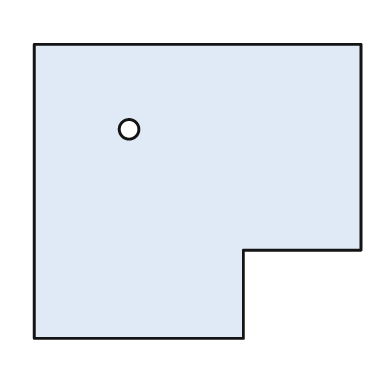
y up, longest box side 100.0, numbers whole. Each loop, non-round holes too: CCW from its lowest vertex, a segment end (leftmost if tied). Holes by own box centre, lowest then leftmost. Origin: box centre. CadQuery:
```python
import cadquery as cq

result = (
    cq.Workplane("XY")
    .moveTo(-50.0, -45.0)
    .lineTo(14.0, -45.0)
    .lineTo(14.0, -18.0)
    .lineTo(50.0, -18.0)
    .lineTo(50.0, 45.0)
    .lineTo(-50.0, 45.0)
    .close()
    .moveTo(-21.0, 19.0)
    .circle(3.0)
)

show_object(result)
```